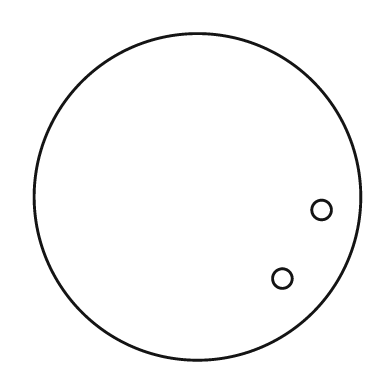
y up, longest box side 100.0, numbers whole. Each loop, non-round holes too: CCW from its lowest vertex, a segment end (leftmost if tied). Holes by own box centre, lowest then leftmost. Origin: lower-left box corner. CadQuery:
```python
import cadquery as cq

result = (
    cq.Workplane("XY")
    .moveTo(50.0, 50.0)
    .circle(50.0)
    .moveTo(76.0, 25.0)
    .circle(3.0)
    .moveTo(88.0, 46.0)
    .circle(3.0)
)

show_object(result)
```